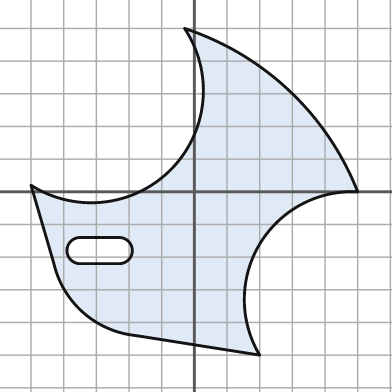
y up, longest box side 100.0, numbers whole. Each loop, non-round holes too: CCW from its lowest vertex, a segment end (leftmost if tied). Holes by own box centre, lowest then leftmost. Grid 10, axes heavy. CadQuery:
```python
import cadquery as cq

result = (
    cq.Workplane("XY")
    .moveTo(20.0, -50.0)
    .threePointArc((20.0, -16.0), (50.0, 0.0))
    .threePointArc((29.0, 31.0), (-3.0, 50.0))
    .threePointArc((-7.0, 7.0), (-50.0, 2.0))
    .lineTo(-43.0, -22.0)
    .threePointArc((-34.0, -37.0), (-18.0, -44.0))
    .close()
    .moveTo(-35.0, -22.0)
    .lineTo(-23.0, -22.0)
    .threePointArc((-19.0, -18.0), (-23.0, -14.0))
    .lineTo(-35.0, -14.0)
    .threePointArc((-39.0, -18.0), (-35.0, -22.0))
    .close()
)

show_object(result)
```